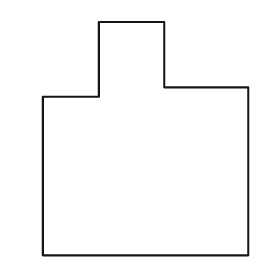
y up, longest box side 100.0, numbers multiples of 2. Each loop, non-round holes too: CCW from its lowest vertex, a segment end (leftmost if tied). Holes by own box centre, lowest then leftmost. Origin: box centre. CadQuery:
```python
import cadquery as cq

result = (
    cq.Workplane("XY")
    .moveTo(-44.0, -50.0)
    .lineTo(44.0, -50.0)
    .lineTo(44.0, 22.0)
    .lineTo(8.0, 22.0)
    .lineTo(8.0, 50.0)
    .lineTo(-20.0, 50.0)
    .lineTo(-20.0, 18.0)
    .lineTo(-44.0, 18.0)
    .close()
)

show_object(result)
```